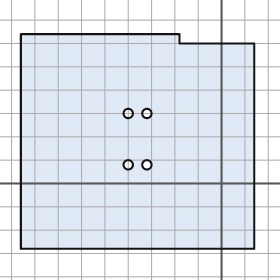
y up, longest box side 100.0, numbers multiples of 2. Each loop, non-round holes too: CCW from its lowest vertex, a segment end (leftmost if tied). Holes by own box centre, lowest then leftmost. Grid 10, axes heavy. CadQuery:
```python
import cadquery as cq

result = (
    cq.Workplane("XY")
    .moveTo(-86.0, -28.0)
    .lineTo(14.0, -28.0)
    .lineTo(14.0, 60.0)
    .lineTo(-18.0, 60.0)
    .lineTo(-18.0, 64.0)
    .lineTo(-86.0, 64.0)
    .close()
    .moveTo(-40.0, 8.0)
    .circle(2.0)
    .moveTo(-32.0, 8.0)
    .circle(2.0)
    .moveTo(-40.0, 30.0)
    .circle(2.0)
    .moveTo(-32.0, 30.0)
    .circle(2.0)
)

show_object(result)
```